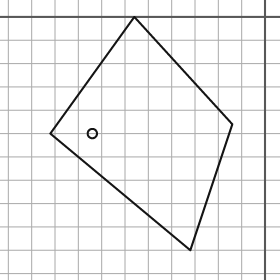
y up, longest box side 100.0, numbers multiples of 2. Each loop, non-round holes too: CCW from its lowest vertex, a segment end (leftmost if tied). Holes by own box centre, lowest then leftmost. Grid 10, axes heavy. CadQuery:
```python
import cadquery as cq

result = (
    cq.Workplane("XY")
    .moveTo(-32.0, -100.0)
    .lineTo(-14.0, -46.0)
    .lineTo(-56.0, 0.0)
    .lineTo(-92.0, -50.0)
    .close()
    .moveTo(-74.0, -50.0)
    .circle(2.0)
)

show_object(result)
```